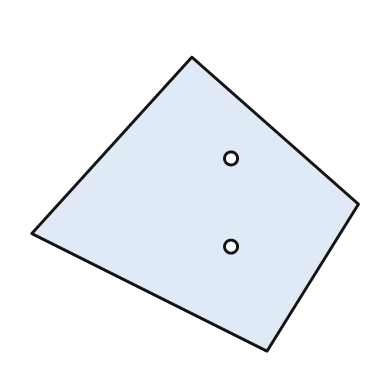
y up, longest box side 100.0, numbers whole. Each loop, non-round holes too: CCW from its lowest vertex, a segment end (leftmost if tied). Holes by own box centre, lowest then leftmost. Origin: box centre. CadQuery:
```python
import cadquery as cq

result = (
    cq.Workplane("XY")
    .moveTo(22.0, -45.0)
    .lineTo(50.0, 0.0)
    .lineTo(-1.0, 45.0)
    .lineTo(-50.0, -9.0)
    .close()
    .moveTo(11.0, -13.0)
    .circle(2.0)
    .moveTo(11.0, 14.0)
    .circle(2.0)
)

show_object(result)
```